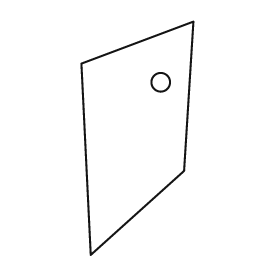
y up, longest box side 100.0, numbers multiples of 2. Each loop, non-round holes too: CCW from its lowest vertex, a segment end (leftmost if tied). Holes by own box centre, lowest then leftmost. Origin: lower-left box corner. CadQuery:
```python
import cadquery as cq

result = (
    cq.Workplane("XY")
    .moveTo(4.0, 0.0)
    .lineTo(44.0, 36.0)
    .lineTo(48.0, 100.0)
    .lineTo(0.0, 82.0)
    .close()
    .moveTo(34.0, 74.0)
    .circle(4.0)
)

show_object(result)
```